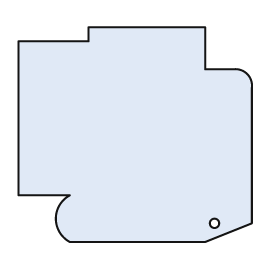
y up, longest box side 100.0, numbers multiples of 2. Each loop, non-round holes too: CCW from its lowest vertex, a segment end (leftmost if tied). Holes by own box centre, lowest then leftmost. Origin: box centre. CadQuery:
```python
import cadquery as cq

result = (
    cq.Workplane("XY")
    .moveTo(-28.0, -46.0)
    .lineTo(30.0, -46.0)
    .lineTo(50.0, -38.0)
    .lineTo(50.0, 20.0)
    .threePointArc((48.0, 26.0), (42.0, 28.0))
    .lineTo(30.0, 28.0)
    .lineTo(30.0, 46.0)
    .lineTo(-20.0, 46.0)
    .lineTo(-20.0, 40.0)
    .lineTo(-50.0, 40.0)
    .lineTo(-50.0, -26.0)
    .lineTo(-28.0, -26.0)
    .threePointArc((-34.0, -36.0), (-28.0, -46.0))
    .close()
    .moveTo(34.0, -38.0)
    .circle(2.0)
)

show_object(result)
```